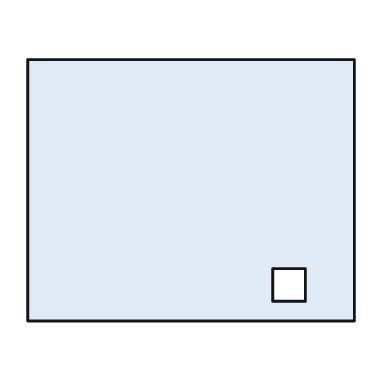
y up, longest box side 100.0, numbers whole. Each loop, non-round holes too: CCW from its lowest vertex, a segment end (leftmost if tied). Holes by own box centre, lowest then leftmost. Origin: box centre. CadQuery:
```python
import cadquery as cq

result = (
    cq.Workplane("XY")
    .moveTo(-50.0, -40.0)
    .lineTo(50.0, -40.0)
    .lineTo(50.0, 40.0)
    .lineTo(-50.0, 40.0)
    .close()
    .moveTo(25.0, -34.0)
    .lineTo(35.0, -34.0)
    .lineTo(35.0, -24.0)
    .lineTo(25.0, -24.0)
    .close()
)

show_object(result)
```